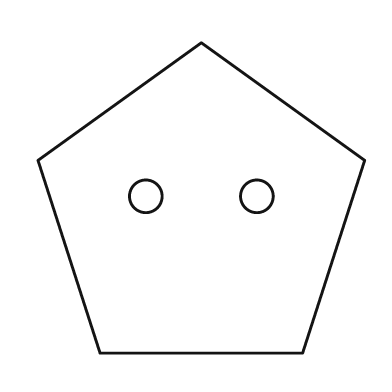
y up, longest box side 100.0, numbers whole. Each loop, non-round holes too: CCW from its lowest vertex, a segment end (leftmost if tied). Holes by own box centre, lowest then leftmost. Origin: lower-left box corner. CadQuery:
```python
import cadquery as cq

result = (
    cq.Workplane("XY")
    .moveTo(19.0, 0.0)
    .lineTo(81.0, 0.0)
    .lineTo(100.0, 59.0)
    .lineTo(50.0, 95.0)
    .lineTo(0.0, 59.0)
    .close()
    .moveTo(33.0, 48.0)
    .circle(5.0)
    .moveTo(67.0, 48.0)
    .circle(5.0)
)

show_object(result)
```